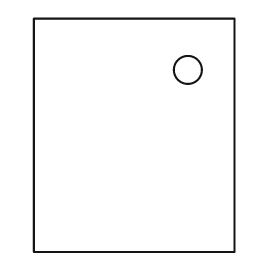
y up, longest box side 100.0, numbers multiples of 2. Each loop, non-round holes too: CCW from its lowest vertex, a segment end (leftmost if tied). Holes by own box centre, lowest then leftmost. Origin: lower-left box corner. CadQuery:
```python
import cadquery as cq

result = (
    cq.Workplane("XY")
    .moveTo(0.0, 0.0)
    .lineTo(86.0, 0.0)
    .lineTo(86.0, 100.0)
    .lineTo(0.0, 100.0)
    .close()
    .moveTo(66.0, 78.0)
    .circle(6.0)
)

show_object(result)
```